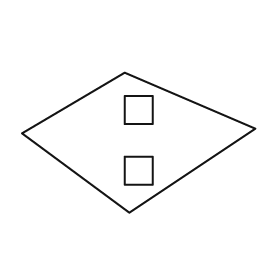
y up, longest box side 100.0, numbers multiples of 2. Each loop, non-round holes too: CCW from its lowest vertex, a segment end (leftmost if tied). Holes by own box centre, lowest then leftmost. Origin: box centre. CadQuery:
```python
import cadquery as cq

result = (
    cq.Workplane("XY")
    .moveTo(-4.0, -30.0)
    .lineTo(50.0, 6.0)
    .lineTo(-6.0, 30.0)
    .lineTo(-50.0, 4.0)
    .close()
    .moveTo(-6.0, -18.0)
    .lineTo(6.0, -18.0)
    .lineTo(6.0, -6.0)
    .lineTo(-6.0, -6.0)
    .close()
    .moveTo(-6.0, 8.0)
    .lineTo(6.0, 8.0)
    .lineTo(6.0, 20.0)
    .lineTo(-6.0, 20.0)
    .close()
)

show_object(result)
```